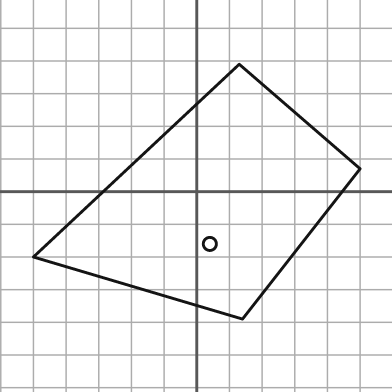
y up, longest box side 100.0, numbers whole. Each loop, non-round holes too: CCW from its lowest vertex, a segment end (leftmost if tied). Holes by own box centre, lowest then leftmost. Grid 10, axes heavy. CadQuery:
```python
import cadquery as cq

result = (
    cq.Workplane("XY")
    .moveTo(14.0, -39.0)
    .lineTo(50.0, 7.0)
    .lineTo(13.0, 39.0)
    .lineTo(-50.0, -20.0)
    .close()
    .moveTo(4.0, -16.0)
    .circle(2.0)
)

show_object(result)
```